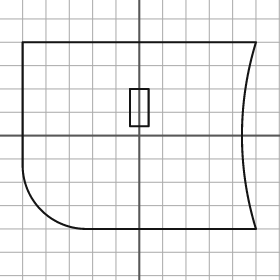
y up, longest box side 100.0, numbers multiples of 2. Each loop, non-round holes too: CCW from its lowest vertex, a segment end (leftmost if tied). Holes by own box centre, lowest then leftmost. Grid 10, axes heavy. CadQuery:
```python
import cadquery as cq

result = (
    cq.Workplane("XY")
    .moveTo(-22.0, -40.0)
    .lineTo(50.0, -40.0)
    .threePointArc((44.0, 0.0), (50.0, 40.0))
    .lineTo(-50.0, 40.0)
    .lineTo(-50.0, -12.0)
    .threePointArc((-42.0, -32.0), (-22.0, -40.0))
    .close()
    .moveTo(-4.0, 4.0)
    .lineTo(4.0, 4.0)
    .lineTo(4.0, 20.0)
    .lineTo(-4.0, 20.0)
    .close()
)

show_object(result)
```